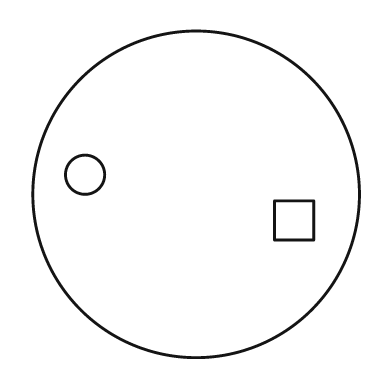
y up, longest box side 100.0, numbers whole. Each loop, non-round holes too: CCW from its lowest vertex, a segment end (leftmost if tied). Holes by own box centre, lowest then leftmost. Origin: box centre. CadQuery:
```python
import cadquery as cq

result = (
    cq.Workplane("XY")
    .moveTo(0.0, 0.0)
    .circle(50.0)
    .moveTo(24.0, -14.0)
    .lineTo(36.0, -14.0)
    .lineTo(36.0, -2.0)
    .lineTo(24.0, -2.0)
    .close()
    .moveTo(-34.0, 6.0)
    .circle(6.0)
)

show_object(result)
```